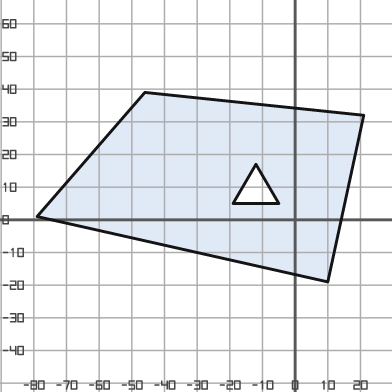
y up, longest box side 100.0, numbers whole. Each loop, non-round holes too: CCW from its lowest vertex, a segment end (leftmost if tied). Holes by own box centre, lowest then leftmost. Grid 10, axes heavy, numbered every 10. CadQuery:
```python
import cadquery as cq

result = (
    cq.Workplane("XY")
    .moveTo(10.0, -19.0)
    .lineTo(21.0, 32.0)
    .lineTo(-46.0, 39.0)
    .lineTo(-79.0, 1.0)
    .close()
    .moveTo(-19.0, 5.0)
    .lineTo(-5.0, 5.0)
    .lineTo(-12.0, 17.0)
    .close()
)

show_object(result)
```